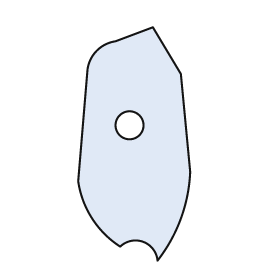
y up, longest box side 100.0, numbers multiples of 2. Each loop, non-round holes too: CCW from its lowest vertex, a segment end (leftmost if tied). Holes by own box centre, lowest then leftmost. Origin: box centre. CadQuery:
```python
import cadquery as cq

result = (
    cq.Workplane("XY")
    .moveTo(10.0, -50.0)
    .threePointArc((20.0, -32.0), (24.0, -12.0))
    .lineTo(20.0, 30.0)
    .lineTo(8.0, 50.0)
    .lineTo(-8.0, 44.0)
    .threePointArc((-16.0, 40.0), (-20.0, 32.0))
    .lineTo(-24.0, -16.0)
    .threePointArc((-18.0, -32.0), (-6.0, -44.0))
    .threePointArc((4.0, -42.0), (10.0, -50.0))
    .close()
    .moveTo(-2.0, 8.0)
    .circle(6.0)
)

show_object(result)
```